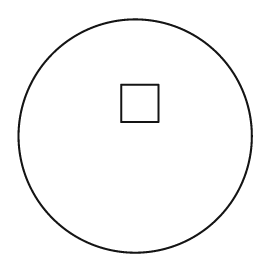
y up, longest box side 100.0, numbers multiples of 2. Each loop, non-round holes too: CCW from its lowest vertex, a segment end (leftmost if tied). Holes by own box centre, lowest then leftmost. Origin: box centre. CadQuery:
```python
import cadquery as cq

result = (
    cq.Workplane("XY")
    .moveTo(0.0, 0.0)
    .circle(50.0)
    .moveTo(-6.0, 6.0)
    .lineTo(10.0, 6.0)
    .lineTo(10.0, 22.0)
    .lineTo(-6.0, 22.0)
    .close()
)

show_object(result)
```